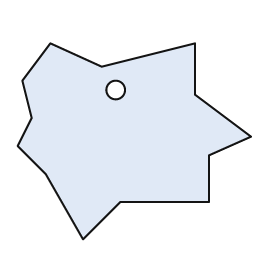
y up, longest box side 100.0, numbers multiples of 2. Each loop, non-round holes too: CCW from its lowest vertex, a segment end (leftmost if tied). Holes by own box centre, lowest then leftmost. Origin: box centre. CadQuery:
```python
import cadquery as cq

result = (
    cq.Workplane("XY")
    .moveTo(-22.0, -42.0)
    .lineTo(-6.0, -26.0)
    .lineTo(32.0, -26.0)
    .lineTo(32.0, -6.0)
    .lineTo(50.0, 2.0)
    .lineTo(26.0, 20.0)
    .lineTo(26.0, 42.0)
    .lineTo(-14.0, 32.0)
    .lineTo(-36.0, 42.0)
    .lineTo(-48.0, 26.0)
    .lineTo(-44.0, 10.0)
    .lineTo(-50.0, -2.0)
    .lineTo(-38.0, -14.0)
    .close()
    .moveTo(-8.0, 22.0)
    .circle(4.0)
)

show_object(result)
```